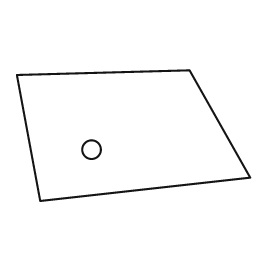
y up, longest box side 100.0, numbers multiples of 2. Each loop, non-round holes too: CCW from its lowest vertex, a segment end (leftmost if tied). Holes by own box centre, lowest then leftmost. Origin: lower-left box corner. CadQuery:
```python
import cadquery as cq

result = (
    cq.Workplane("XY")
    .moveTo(10.0, 0.0)
    .lineTo(100.0, 10.0)
    .lineTo(74.0, 56.0)
    .lineTo(0.0, 54.0)
    .close()
    .moveTo(32.0, 22.0)
    .circle(4.0)
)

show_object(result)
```